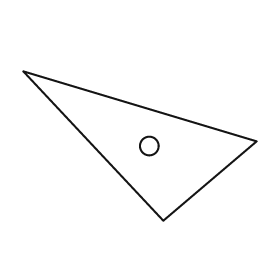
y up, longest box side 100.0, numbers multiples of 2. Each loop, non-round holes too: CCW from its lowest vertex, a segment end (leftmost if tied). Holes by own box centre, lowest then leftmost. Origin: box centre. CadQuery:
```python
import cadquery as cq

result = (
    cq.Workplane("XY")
    .moveTo(10.0, -32.0)
    .lineTo(50.0, 2.0)
    .lineTo(-50.0, 32.0)
    .close()
    .moveTo(4.0, 0.0)
    .circle(4.0)
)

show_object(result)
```